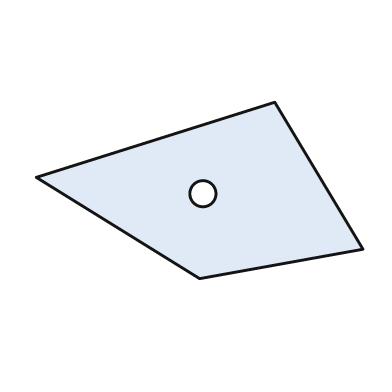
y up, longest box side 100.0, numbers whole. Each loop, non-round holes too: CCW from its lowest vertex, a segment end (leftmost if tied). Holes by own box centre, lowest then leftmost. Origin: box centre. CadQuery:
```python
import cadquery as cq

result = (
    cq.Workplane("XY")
    .moveTo(0.0, -27.0)
    .lineTo(50.0, -18.0)
    .lineTo(23.0, 27.0)
    .lineTo(-50.0, 4.0)
    .close()
    .moveTo(1.0, -1.0)
    .circle(4.0)
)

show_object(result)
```